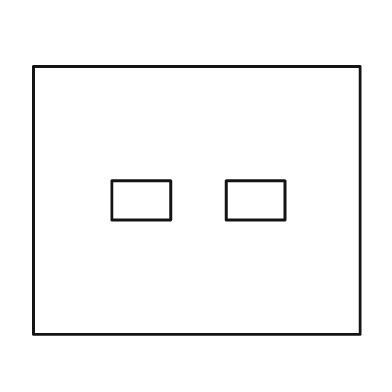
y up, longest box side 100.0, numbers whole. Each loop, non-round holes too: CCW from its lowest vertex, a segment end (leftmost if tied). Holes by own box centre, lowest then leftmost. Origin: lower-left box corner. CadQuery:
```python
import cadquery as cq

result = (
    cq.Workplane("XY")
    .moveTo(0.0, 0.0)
    .lineTo(100.0, 0.0)
    .lineTo(100.0, 82.0)
    .lineTo(0.0, 82.0)
    .close()
    .moveTo(24.0, 35.0)
    .lineTo(42.0, 35.0)
    .lineTo(42.0, 47.0)
    .lineTo(24.0, 47.0)
    .close()
    .moveTo(59.0, 35.0)
    .lineTo(77.0, 35.0)
    .lineTo(77.0, 47.0)
    .lineTo(59.0, 47.0)
    .close()
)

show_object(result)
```